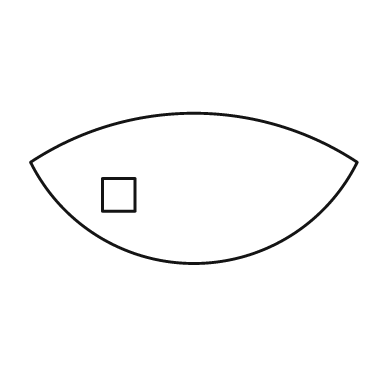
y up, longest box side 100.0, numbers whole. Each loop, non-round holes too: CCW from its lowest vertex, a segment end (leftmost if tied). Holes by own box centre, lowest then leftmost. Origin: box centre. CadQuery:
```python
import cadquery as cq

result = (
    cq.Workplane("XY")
    .moveTo(-50.0, 8.0)
    .threePointArc((0.0, -23.0), (50.0, 8.0))
    .threePointArc((0.0, 23.0), (-50.0, 8.0))
    .close()
    .moveTo(-28.0, -7.0)
    .lineTo(-18.0, -7.0)
    .lineTo(-18.0, 3.0)
    .lineTo(-28.0, 3.0)
    .close()
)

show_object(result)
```